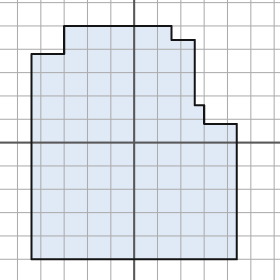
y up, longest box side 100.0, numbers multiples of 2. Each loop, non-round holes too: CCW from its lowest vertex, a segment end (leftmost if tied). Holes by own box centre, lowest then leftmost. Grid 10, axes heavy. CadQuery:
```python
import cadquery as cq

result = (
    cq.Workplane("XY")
    .moveTo(-44.0, -50.0)
    .lineTo(44.0, -50.0)
    .lineTo(44.0, 8.0)
    .lineTo(30.0, 8.0)
    .lineTo(30.0, 16.0)
    .lineTo(26.0, 16.0)
    .lineTo(26.0, 44.0)
    .lineTo(16.0, 44.0)
    .lineTo(16.0, 50.0)
    .lineTo(-30.0, 50.0)
    .lineTo(-30.0, 38.0)
    .lineTo(-44.0, 38.0)
    .close()
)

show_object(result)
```